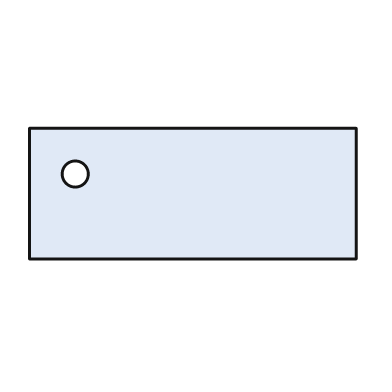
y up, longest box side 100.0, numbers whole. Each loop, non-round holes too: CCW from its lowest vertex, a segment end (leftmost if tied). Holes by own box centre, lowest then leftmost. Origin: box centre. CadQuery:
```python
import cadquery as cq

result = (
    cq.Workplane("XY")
    .moveTo(-50.0, -20.0)
    .lineTo(50.0, -20.0)
    .lineTo(50.0, 20.0)
    .lineTo(-50.0, 20.0)
    .close()
    .moveTo(-36.0, 6.0)
    .circle(4.0)
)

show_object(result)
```